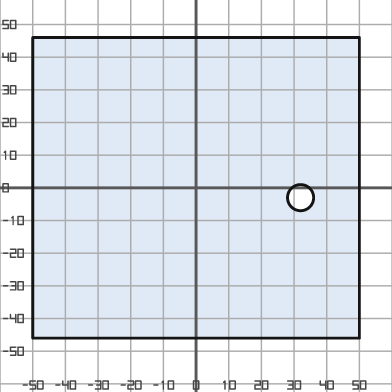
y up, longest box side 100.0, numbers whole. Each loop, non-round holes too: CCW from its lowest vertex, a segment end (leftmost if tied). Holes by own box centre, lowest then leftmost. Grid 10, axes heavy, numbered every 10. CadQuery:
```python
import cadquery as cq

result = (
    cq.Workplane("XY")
    .moveTo(-50.0, -46.0)
    .lineTo(50.0, -46.0)
    .lineTo(50.0, 46.0)
    .lineTo(-50.0, 46.0)
    .close()
    .moveTo(32.0, -3.0)
    .circle(4.0)
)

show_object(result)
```